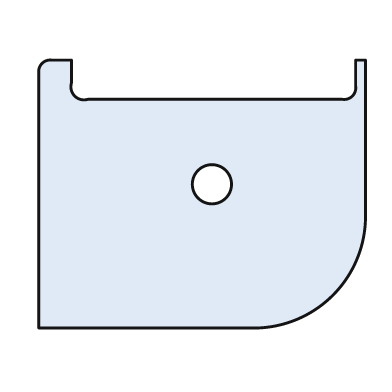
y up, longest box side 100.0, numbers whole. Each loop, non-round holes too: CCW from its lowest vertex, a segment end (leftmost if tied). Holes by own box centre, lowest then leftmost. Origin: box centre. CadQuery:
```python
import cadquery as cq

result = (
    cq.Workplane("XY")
    .moveTo(-50.0, -41.0)
    .lineTo(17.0, -41.0)
    .threePointArc((40.0, -31.0), (50.0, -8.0))
    .lineTo(50.0, 41.0)
    .lineTo(47.0, 41.0)
    .lineTo(47.0, 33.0)
    .threePointArc((46.0, 30.0), (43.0, 29.0))
    .lineTo(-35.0, 29.0)
    .threePointArc((-39.0, 30.0), (-40.0, 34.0))
    .lineTo(-40.0, 41.0)
    .lineTo(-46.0, 41.0)
    .threePointArc((-49.0, 40.0), (-50.0, 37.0))
    .close()
    .moveTo(3.0, 3.0)
    .circle(6.0)
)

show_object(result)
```